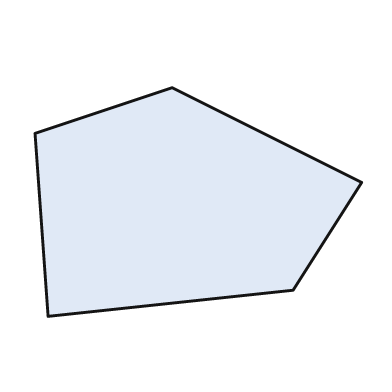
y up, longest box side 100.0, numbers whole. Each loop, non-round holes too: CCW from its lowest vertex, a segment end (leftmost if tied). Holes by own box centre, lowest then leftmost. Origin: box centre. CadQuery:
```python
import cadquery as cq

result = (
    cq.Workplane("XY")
    .moveTo(-46.0, -35.0)
    .lineTo(29.0, -27.0)
    .lineTo(50.0, 6.0)
    .lineTo(-8.0, 35.0)
    .lineTo(-50.0, 21.0)
    .close()
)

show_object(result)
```